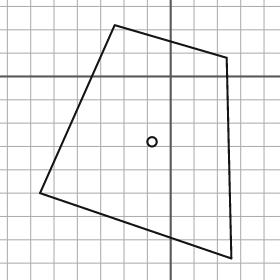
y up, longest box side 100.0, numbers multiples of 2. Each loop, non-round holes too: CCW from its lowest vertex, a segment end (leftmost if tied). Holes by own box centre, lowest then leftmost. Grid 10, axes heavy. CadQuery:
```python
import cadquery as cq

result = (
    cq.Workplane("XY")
    .moveTo(26.0, -78.0)
    .lineTo(24.0, 8.0)
    .lineTo(-24.0, 22.0)
    .lineTo(-56.0, -50.0)
    .close()
    .moveTo(-8.0, -28.0)
    .circle(2.0)
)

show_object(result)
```